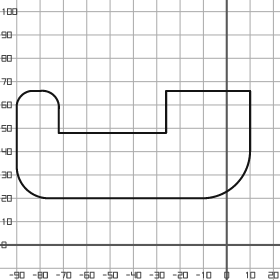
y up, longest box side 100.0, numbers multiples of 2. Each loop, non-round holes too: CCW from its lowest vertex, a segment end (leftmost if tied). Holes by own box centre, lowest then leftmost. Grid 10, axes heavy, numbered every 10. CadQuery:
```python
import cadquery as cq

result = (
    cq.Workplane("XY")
    .moveTo(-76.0, 20.0)
    .lineTo(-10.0, 20.0)
    .threePointArc((4.0, 26.0), (10.0, 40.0))
    .lineTo(10.0, 66.0)
    .lineTo(-26.0, 66.0)
    .lineTo(-26.0, 48.0)
    .lineTo(-72.0, 48.0)
    .lineTo(-72.0, 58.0)
    .threePointArc((-74.0, 64.0), (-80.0, 66.0))
    .lineTo(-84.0, 66.0)
    .threePointArc((-88.0, 64.0), (-90.0, 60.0))
    .lineTo(-90.0, 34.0)
    .threePointArc((-86.0, 24.0), (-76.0, 20.0))
    .close()
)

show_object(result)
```